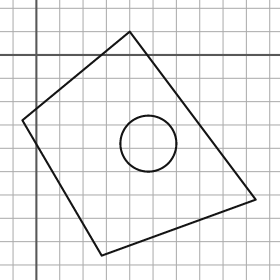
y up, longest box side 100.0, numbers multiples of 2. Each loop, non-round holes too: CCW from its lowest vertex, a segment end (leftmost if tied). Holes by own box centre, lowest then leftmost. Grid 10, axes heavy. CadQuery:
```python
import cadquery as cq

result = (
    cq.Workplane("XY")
    .moveTo(28.0, -86.0)
    .lineTo(94.0, -62.0)
    .lineTo(40.0, 10.0)
    .lineTo(-6.0, -28.0)
    .close()
    .moveTo(48.0, -38.0)
    .circle(12.0)
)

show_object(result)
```